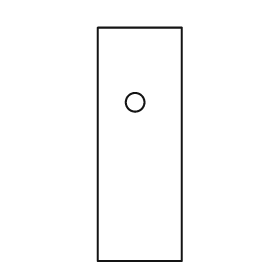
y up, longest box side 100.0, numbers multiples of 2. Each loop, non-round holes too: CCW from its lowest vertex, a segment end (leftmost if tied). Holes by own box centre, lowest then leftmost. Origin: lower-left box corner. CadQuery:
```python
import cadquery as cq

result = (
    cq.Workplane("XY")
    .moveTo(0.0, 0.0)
    .lineTo(36.0, 0.0)
    .lineTo(36.0, 100.0)
    .lineTo(0.0, 100.0)
    .close()
    .moveTo(16.0, 68.0)
    .circle(4.0)
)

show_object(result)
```